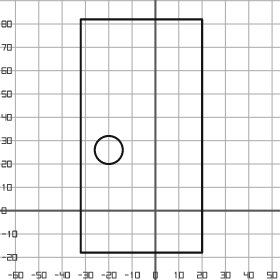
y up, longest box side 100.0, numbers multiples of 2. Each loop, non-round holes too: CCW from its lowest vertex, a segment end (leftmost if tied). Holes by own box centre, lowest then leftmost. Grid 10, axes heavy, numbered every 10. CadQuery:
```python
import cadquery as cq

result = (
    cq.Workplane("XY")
    .moveTo(-32.0, -18.0)
    .lineTo(20.0, -18.0)
    .lineTo(20.0, 82.0)
    .lineTo(-32.0, 82.0)
    .close()
    .moveTo(-20.0, 26.0)
    .circle(6.0)
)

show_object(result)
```